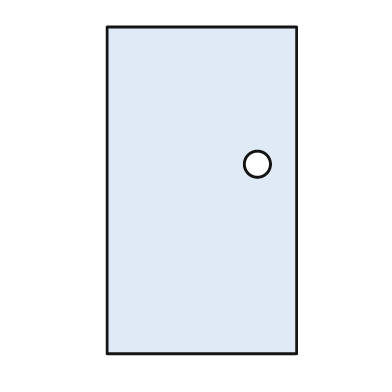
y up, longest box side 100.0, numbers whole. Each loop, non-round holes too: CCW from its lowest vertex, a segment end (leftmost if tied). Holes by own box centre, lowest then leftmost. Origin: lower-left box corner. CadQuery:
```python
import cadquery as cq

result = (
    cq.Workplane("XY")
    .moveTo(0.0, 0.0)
    .lineTo(58.0, 0.0)
    .lineTo(58.0, 100.0)
    .lineTo(0.0, 100.0)
    .close()
    .moveTo(46.0, 58.0)
    .circle(4.0)
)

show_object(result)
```